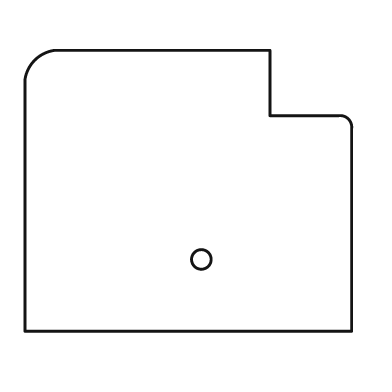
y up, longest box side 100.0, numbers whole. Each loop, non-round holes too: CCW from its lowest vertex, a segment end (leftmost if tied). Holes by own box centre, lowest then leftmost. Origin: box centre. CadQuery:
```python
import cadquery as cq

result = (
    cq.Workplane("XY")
    .moveTo(-50.0, -43.0)
    .lineTo(50.0, -43.0)
    .lineTo(50.0, 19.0)
    .threePointArc((49.0, 22.0), (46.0, 23.0))
    .lineTo(25.0, 23.0)
    .lineTo(25.0, 43.0)
    .lineTo(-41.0, 43.0)
    .threePointArc((-47.0, 40.0), (-50.0, 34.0))
    .close()
    .moveTo(4.0, -21.0)
    .circle(3.0)
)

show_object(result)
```